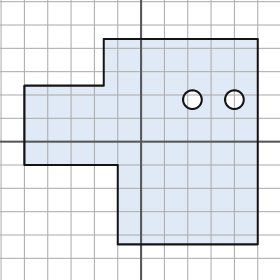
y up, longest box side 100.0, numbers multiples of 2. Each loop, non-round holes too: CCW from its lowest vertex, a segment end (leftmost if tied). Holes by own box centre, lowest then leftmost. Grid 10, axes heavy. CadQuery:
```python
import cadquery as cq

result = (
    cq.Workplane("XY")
    .moveTo(-10.0, -44.0)
    .lineTo(50.0, -44.0)
    .lineTo(50.0, 44.0)
    .lineTo(-16.0, 44.0)
    .lineTo(-16.0, 24.0)
    .lineTo(-50.0, 24.0)
    .lineTo(-50.0, -10.0)
    .lineTo(-10.0, -10.0)
    .close()
    .moveTo(22.0, 18.0)
    .circle(4.0)
    .moveTo(40.0, 18.0)
    .circle(4.0)
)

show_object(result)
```